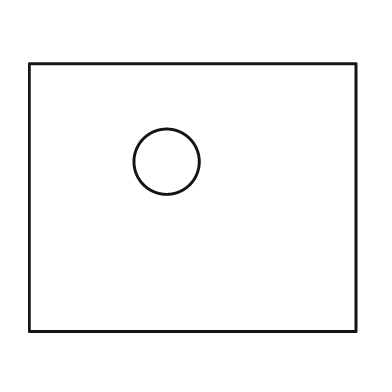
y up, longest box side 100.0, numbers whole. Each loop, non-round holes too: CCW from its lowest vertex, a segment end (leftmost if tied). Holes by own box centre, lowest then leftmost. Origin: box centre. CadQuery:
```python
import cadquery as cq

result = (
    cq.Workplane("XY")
    .moveTo(-50.0, -41.0)
    .lineTo(50.0, -41.0)
    .lineTo(50.0, 41.0)
    .lineTo(-50.0, 41.0)
    .close()
    .moveTo(-8.0, 11.0)
    .circle(10.0)
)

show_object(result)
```